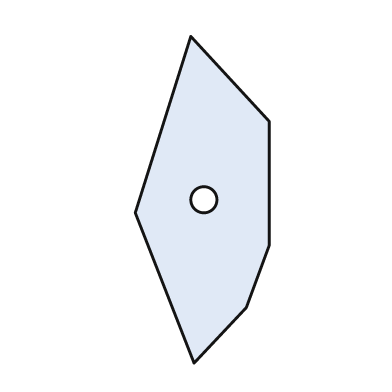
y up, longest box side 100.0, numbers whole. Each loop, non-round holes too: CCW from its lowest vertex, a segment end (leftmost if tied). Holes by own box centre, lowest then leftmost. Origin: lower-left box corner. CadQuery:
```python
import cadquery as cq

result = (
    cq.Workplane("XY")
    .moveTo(18.0, 0.0)
    .lineTo(34.0, 17.0)
    .lineTo(41.0, 36.0)
    .lineTo(41.0, 74.0)
    .lineTo(17.0, 100.0)
    .lineTo(0.0, 46.0)
    .close()
    .moveTo(21.0, 50.0)
    .circle(4.0)
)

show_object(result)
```